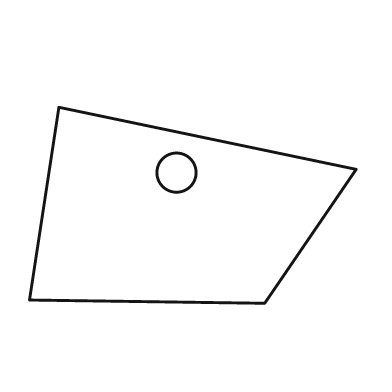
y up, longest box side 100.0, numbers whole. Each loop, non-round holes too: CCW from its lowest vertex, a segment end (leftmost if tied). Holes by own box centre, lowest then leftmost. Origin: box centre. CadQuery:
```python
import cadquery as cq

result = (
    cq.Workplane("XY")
    .moveTo(22.0, -30.0)
    .lineTo(50.0, 11.0)
    .lineTo(-41.0, 30.0)
    .lineTo(-50.0, -29.0)
    .close()
    .moveTo(-5.0, 10.0)
    .circle(6.0)
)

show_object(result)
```